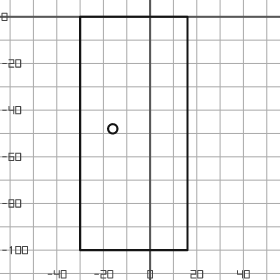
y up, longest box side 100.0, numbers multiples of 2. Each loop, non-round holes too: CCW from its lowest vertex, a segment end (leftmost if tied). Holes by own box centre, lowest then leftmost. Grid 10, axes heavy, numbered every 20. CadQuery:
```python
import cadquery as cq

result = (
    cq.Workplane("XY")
    .moveTo(-30.0, -100.0)
    .lineTo(16.0, -100.0)
    .lineTo(16.0, 0.0)
    .lineTo(-30.0, 0.0)
    .close()
    .moveTo(-16.0, -48.0)
    .circle(2.0)
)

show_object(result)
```